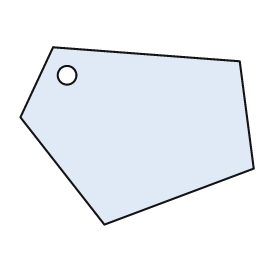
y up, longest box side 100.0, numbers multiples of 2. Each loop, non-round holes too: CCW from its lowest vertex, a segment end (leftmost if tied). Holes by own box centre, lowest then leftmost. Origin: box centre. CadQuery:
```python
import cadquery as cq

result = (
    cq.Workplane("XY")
    .moveTo(-14.0, -38.0)
    .lineTo(50.0, -14.0)
    .lineTo(44.0, 32.0)
    .lineTo(-36.0, 38.0)
    .lineTo(-50.0, 8.0)
    .close()
    .moveTo(-30.0, 26.0)
    .circle(4.0)
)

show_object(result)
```